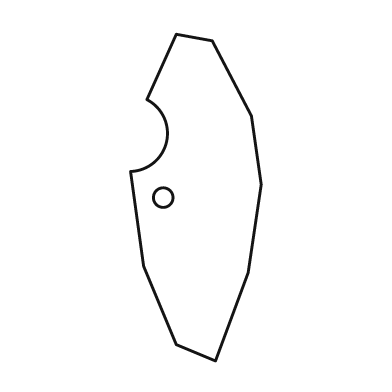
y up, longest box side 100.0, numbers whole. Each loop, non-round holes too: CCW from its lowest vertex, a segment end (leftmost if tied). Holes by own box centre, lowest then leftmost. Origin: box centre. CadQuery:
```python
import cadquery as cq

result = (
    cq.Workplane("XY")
    .moveTo(6.0, -50.0)
    .lineTo(16.0, -23.0)
    .lineTo(20.0, 4.0)
    .lineTo(17.0, 25.0)
    .lineTo(5.0, 48.0)
    .lineTo(-6.0, 50.0)
    .lineTo(-15.0, 30.0)
    .threePointArc((-9.0, 17.0), (-20.0, 8.0))
    .lineTo(-16.0, -21.0)
    .lineTo(-6.0, -45.0)
    .close()
    .moveTo(-10.0, 0.0)
    .circle(3.0)
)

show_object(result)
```